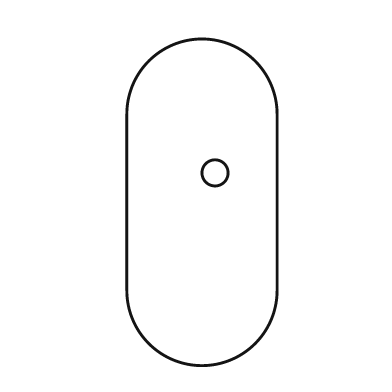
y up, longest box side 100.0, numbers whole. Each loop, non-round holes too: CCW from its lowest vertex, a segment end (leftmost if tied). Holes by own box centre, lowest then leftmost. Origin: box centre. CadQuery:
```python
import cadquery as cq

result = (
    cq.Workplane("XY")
    .moveTo(-23.0, -27.0)
    .threePointArc((0.0, -50.0), (23.0, -27.0))
    .lineTo(23.0, 27.0)
    .threePointArc((0.0, 50.0), (-23.0, 27.0))
    .close()
    .moveTo(4.0, 9.0)
    .circle(4.0)
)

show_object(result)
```